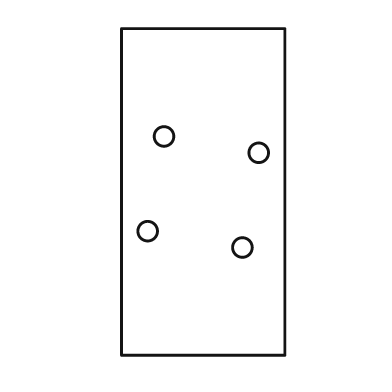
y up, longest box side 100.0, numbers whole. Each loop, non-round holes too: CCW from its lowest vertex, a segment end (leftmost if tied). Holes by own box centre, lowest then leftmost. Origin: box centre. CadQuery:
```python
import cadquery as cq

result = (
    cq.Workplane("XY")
    .moveTo(-25.0, -50.0)
    .lineTo(25.0, -50.0)
    .lineTo(25.0, 50.0)
    .lineTo(-25.0, 50.0)
    .close()
    .moveTo(12.0, -17.0)
    .circle(3.0)
    .moveTo(-17.0, -12.0)
    .circle(3.0)
    .moveTo(17.0, 12.0)
    .circle(3.0)
    .moveTo(-12.0, 17.0)
    .circle(3.0)
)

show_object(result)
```